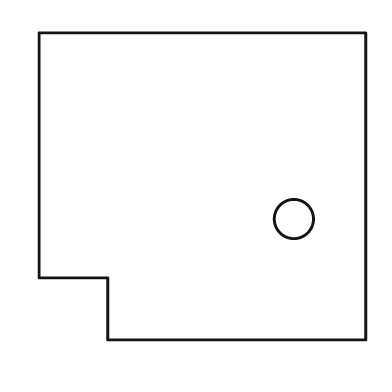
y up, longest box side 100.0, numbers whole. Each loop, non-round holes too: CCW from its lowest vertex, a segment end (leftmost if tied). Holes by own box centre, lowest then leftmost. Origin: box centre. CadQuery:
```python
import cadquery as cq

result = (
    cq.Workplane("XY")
    .moveTo(-29.0, -47.0)
    .lineTo(50.0, -47.0)
    .lineTo(50.0, 47.0)
    .lineTo(-50.0, 47.0)
    .lineTo(-50.0, -28.0)
    .lineTo(-29.0, -28.0)
    .close()
    .moveTo(28.0, -10.0)
    .circle(6.0)
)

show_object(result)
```